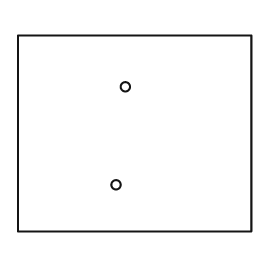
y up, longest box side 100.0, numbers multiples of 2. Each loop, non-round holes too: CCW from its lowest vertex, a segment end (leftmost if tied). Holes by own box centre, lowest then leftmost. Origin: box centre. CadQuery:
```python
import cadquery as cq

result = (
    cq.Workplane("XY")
    .moveTo(-50.0, -42.0)
    .lineTo(50.0, -42.0)
    .lineTo(50.0, 42.0)
    .lineTo(-50.0, 42.0)
    .close()
    .moveTo(-8.0, -22.0)
    .circle(2.0)
    .moveTo(-4.0, 20.0)
    .circle(2.0)
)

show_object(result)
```